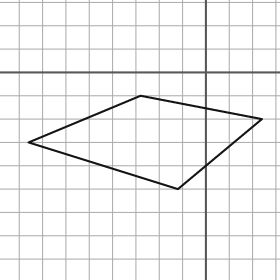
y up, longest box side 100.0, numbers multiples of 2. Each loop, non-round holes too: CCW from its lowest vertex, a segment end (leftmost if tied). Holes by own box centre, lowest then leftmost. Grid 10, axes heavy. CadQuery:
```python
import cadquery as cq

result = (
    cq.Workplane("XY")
    .moveTo(-12.0, -50.0)
    .lineTo(24.0, -20.0)
    .lineTo(-28.0, -10.0)
    .lineTo(-76.0, -30.0)
    .close()
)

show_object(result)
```